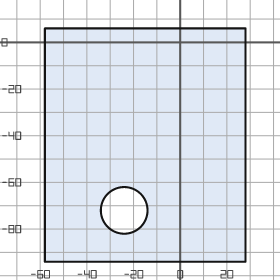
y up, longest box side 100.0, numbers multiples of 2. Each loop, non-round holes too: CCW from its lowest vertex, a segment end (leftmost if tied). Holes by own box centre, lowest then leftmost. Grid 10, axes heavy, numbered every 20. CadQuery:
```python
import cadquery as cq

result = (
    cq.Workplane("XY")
    .moveTo(-58.0, -94.0)
    .lineTo(28.0, -94.0)
    .lineTo(28.0, 6.0)
    .lineTo(-58.0, 6.0)
    .close()
    .moveTo(-24.0, -72.0)
    .circle(10.0)
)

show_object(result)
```